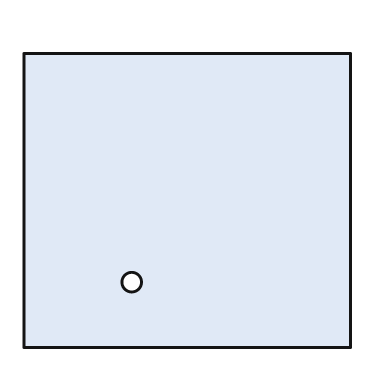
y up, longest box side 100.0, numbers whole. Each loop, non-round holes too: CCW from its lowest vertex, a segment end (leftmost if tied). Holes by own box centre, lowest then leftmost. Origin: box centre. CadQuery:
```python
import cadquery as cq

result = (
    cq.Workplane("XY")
    .moveTo(-50.0, -45.0)
    .lineTo(50.0, -45.0)
    .lineTo(50.0, 45.0)
    .lineTo(-50.0, 45.0)
    .close()
    .moveTo(-17.0, -25.0)
    .circle(3.0)
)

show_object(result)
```